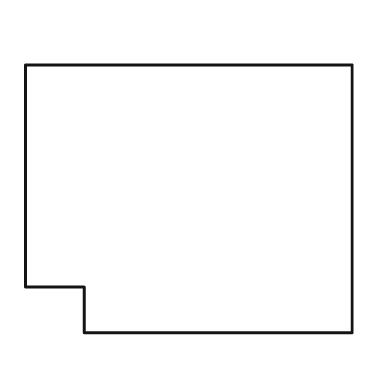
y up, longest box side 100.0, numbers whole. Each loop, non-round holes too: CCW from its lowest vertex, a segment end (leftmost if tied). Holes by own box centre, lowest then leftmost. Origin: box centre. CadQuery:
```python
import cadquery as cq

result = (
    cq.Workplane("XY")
    .moveTo(-32.0, -41.0)
    .lineTo(50.0, -41.0)
    .lineTo(50.0, 41.0)
    .lineTo(-50.0, 41.0)
    .lineTo(-50.0, -27.0)
    .lineTo(-32.0, -27.0)
    .close()
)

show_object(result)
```